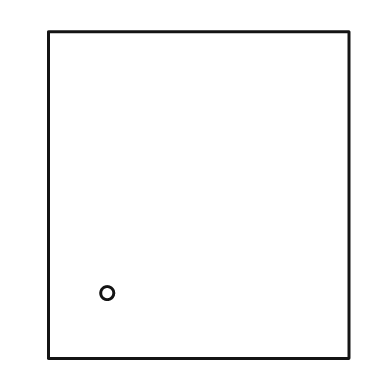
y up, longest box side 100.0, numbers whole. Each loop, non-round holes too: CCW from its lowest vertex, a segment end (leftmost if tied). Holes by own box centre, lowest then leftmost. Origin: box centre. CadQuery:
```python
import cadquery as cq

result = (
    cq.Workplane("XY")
    .moveTo(-46.0, -50.0)
    .lineTo(46.0, -50.0)
    .lineTo(46.0, 50.0)
    .lineTo(-46.0, 50.0)
    .close()
    .moveTo(-28.0, -30.0)
    .circle(2.0)
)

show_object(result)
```